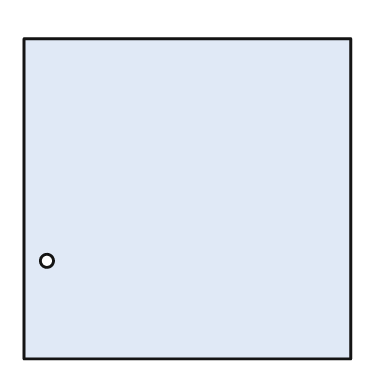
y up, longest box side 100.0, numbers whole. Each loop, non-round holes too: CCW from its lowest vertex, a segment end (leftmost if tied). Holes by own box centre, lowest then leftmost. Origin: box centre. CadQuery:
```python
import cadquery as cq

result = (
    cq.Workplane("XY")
    .moveTo(-50.0, -49.0)
    .lineTo(50.0, -49.0)
    .lineTo(50.0, 49.0)
    .lineTo(-50.0, 49.0)
    .close()
    .moveTo(-43.0, -19.0)
    .circle(2.0)
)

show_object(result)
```